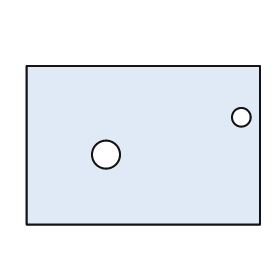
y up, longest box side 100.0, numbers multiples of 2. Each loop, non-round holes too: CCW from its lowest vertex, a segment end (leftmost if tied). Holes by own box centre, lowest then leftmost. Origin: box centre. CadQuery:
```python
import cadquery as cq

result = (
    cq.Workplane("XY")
    .moveTo(-50.0, -34.0)
    .lineTo(50.0, -34.0)
    .lineTo(50.0, 34.0)
    .lineTo(-50.0, 34.0)
    .close()
    .moveTo(-16.0, -4.0)
    .circle(6.0)
    .moveTo(42.0, 12.0)
    .circle(4.0)
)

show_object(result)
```